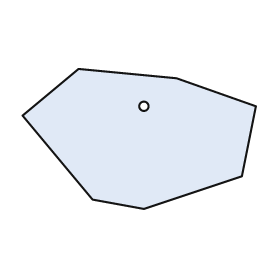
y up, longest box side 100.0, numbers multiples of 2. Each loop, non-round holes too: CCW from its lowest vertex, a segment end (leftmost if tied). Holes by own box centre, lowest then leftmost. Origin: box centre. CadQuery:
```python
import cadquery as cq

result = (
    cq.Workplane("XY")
    .moveTo(2.0, -30.0)
    .lineTo(44.0, -16.0)
    .lineTo(50.0, 14.0)
    .lineTo(16.0, 26.0)
    .lineTo(-26.0, 30.0)
    .lineTo(-50.0, 10.0)
    .lineTo(-20.0, -26.0)
    .close()
    .moveTo(2.0, 14.0)
    .circle(2.0)
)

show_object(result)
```